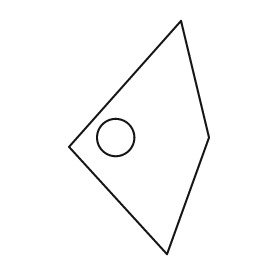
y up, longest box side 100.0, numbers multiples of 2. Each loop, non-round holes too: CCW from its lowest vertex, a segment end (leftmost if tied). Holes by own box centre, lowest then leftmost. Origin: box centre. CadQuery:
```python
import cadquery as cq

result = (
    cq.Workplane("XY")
    .moveTo(12.0, -50.0)
    .lineTo(30.0, 0.0)
    .lineTo(18.0, 50.0)
    .lineTo(-30.0, -4.0)
    .close()
    .moveTo(-10.0, 0.0)
    .circle(8.0)
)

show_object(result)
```